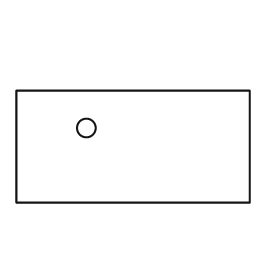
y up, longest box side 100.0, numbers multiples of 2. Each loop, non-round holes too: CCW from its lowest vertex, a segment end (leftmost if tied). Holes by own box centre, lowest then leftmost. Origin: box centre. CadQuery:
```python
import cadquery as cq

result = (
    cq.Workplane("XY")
    .moveTo(-50.0, -24.0)
    .lineTo(50.0, -24.0)
    .lineTo(50.0, 24.0)
    .lineTo(-50.0, 24.0)
    .close()
    .moveTo(-20.0, 8.0)
    .circle(4.0)
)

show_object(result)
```